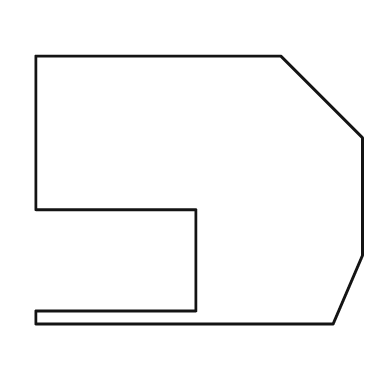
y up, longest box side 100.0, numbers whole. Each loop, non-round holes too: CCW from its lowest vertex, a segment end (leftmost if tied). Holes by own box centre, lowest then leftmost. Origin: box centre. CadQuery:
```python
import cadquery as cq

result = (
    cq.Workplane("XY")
    .moveTo(-50.0, -41.0)
    .lineTo(41.0, -41.0)
    .lineTo(50.0, -20.0)
    .lineTo(50.0, 16.0)
    .lineTo(25.0, 41.0)
    .lineTo(-50.0, 41.0)
    .lineTo(-50.0, -6.0)
    .lineTo(-1.0, -6.0)
    .lineTo(-1.0, -37.0)
    .lineTo(-50.0, -37.0)
    .close()
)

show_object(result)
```